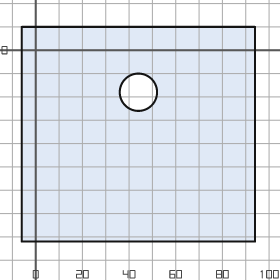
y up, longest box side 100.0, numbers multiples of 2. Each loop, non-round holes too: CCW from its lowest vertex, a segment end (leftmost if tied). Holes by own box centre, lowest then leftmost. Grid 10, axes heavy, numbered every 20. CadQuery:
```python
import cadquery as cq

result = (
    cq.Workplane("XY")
    .moveTo(-6.0, -82.0)
    .lineTo(94.0, -82.0)
    .lineTo(94.0, 10.0)
    .lineTo(-6.0, 10.0)
    .close()
    .moveTo(44.0, -18.0)
    .circle(8.0)
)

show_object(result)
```